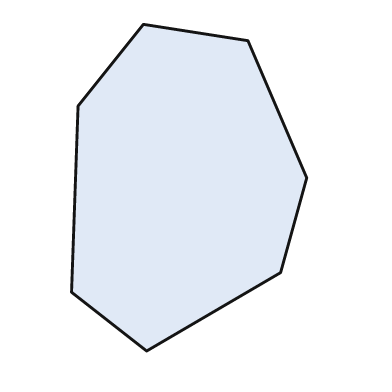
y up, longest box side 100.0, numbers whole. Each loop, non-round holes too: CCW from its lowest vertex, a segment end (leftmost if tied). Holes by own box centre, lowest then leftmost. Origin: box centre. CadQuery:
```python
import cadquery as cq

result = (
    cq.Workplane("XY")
    .moveTo(-13.0, -50.0)
    .lineTo(28.0, -26.0)
    .lineTo(36.0, 3.0)
    .lineTo(18.0, 45.0)
    .lineTo(-14.0, 50.0)
    .lineTo(-34.0, 25.0)
    .lineTo(-36.0, -32.0)
    .close()
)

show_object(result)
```